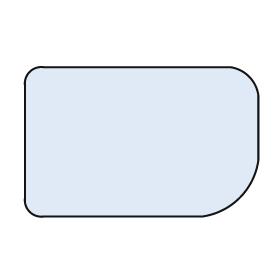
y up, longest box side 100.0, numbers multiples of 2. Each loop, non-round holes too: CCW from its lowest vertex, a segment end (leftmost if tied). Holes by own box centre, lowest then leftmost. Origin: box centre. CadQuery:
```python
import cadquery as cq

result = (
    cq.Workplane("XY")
    .moveTo(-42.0, -32.0)
    .lineTo(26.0, -32.0)
    .threePointArc((42.0, -24.0), (50.0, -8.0))
    .lineTo(50.0, 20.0)
    .threePointArc((46.0, 28.0), (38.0, 32.0))
    .lineTo(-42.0, 32.0)
    .threePointArc((-48.0, 30.0), (-50.0, 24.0))
    .lineTo(-50.0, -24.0)
    .threePointArc((-48.0, -30.0), (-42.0, -32.0))
    .close()
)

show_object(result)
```